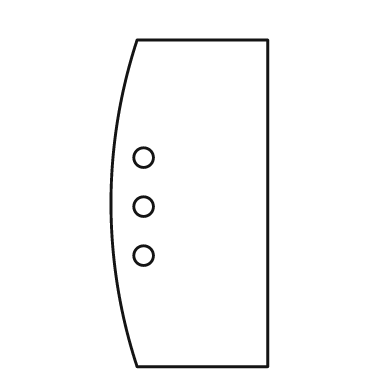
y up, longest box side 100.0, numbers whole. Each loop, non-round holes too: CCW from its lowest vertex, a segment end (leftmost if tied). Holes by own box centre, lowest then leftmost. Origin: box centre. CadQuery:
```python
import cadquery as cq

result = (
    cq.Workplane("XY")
    .moveTo(-16.0, -50.0)
    .lineTo(24.0, -50.0)
    .lineTo(24.0, 50.0)
    .lineTo(-16.0, 50.0)
    .threePointArc((-24.0, 0.0), (-16.0, -50.0))
    .close()
    .moveTo(-14.0, -16.0)
    .circle(3.0)
    .moveTo(-14.0, -1.0)
    .circle(3.0)
    .moveTo(-14.0, 14.0)
    .circle(3.0)
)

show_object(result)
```